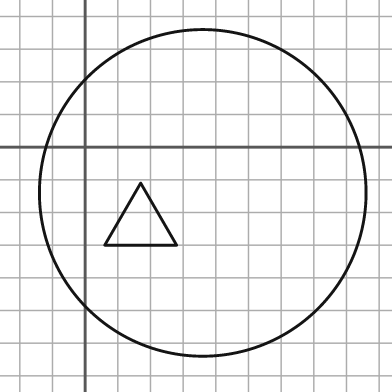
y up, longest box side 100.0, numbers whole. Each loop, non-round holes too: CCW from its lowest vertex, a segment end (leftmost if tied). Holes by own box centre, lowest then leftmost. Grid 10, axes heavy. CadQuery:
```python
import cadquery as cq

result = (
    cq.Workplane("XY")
    .moveTo(36.0, -14.0)
    .circle(50.0)
    .moveTo(6.0, -30.0)
    .lineTo(28.0, -30.0)
    .lineTo(17.0, -11.0)
    .close()
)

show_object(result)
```